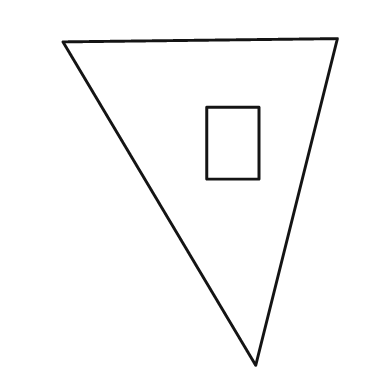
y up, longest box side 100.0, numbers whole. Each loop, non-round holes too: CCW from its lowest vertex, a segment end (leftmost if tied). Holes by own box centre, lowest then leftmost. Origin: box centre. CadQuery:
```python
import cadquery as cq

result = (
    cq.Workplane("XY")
    .moveTo(17.0, -50.0)
    .lineTo(42.0, 50.0)
    .lineTo(-42.0, 49.0)
    .close()
    .moveTo(2.0, 7.0)
    .lineTo(18.0, 7.0)
    .lineTo(18.0, 29.0)
    .lineTo(2.0, 29.0)
    .close()
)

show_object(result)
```